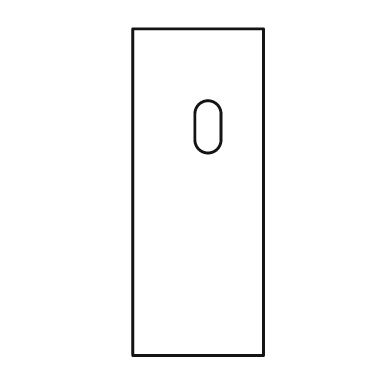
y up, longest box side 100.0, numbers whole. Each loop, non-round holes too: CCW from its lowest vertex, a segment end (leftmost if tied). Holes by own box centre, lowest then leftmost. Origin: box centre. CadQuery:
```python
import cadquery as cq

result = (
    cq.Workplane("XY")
    .moveTo(-20.0, -50.0)
    .lineTo(20.0, -50.0)
    .lineTo(20.0, 50.0)
    .lineTo(-20.0, 50.0)
    .close()
    .moveTo(-1.0, 16.0)
    .threePointArc((3.0, 12.0), (7.0, 16.0))
    .lineTo(7.0, 24.0)
    .threePointArc((3.0, 28.0), (-1.0, 24.0))
    .close()
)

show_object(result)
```